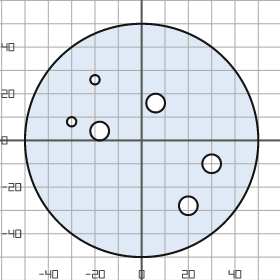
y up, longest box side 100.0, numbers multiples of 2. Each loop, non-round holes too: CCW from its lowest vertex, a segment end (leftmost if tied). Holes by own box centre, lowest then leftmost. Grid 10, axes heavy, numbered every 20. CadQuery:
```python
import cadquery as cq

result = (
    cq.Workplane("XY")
    .moveTo(0.0, 0.0)
    .circle(50.0)
    .moveTo(20.0, -28.0)
    .circle(4.0)
    .moveTo(30.0, -10.0)
    .circle(4.0)
    .moveTo(-18.0, 4.0)
    .circle(4.0)
    .moveTo(-30.0, 8.0)
    .circle(2.0)
    .moveTo(6.0, 16.0)
    .circle(4.0)
    .moveTo(-20.0, 26.0)
    .circle(2.0)
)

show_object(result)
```